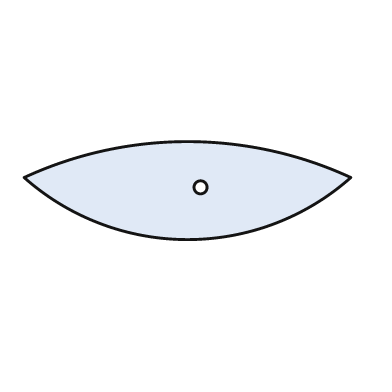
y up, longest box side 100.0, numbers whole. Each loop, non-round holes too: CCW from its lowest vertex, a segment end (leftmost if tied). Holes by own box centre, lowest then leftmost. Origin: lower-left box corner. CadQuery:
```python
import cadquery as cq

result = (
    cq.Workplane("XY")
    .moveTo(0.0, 19.0)
    .threePointArc((50.0, 0.0), (100.0, 19.0))
    .threePointArc((50.0, 30.0), (0.0, 19.0))
    .close()
    .moveTo(54.0, 16.0)
    .circle(2.0)
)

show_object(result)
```